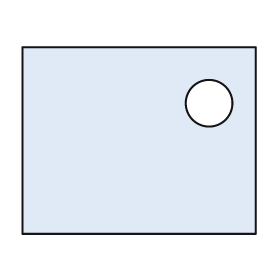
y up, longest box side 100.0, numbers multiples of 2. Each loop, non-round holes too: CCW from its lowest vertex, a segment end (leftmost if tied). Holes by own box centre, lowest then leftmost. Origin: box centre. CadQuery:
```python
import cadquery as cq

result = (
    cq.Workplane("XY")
    .moveTo(-50.0, -40.0)
    .lineTo(50.0, -40.0)
    .lineTo(50.0, 40.0)
    .lineTo(-50.0, 40.0)
    .close()
    .moveTo(30.0, 16.0)
    .circle(10.0)
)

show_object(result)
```